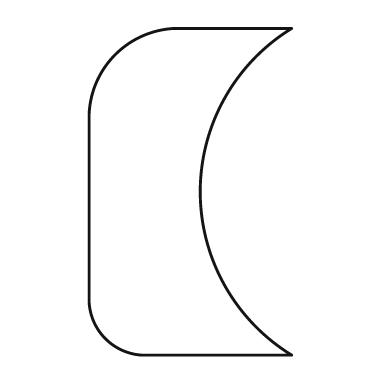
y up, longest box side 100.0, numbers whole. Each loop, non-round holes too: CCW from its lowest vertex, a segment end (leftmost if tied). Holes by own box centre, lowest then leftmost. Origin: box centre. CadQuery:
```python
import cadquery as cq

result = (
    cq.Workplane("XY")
    .moveTo(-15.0, -50.0)
    .lineTo(31.0, -50.0)
    .threePointArc((3.0, 0.0), (31.0, 50.0))
    .lineTo(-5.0, 50.0)
    .threePointArc((-23.0, 42.0), (-31.0, 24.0))
    .lineTo(-31.0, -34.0)
    .threePointArc((-26.0, -45.0), (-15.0, -50.0))
    .close()
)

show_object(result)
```